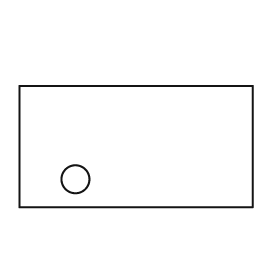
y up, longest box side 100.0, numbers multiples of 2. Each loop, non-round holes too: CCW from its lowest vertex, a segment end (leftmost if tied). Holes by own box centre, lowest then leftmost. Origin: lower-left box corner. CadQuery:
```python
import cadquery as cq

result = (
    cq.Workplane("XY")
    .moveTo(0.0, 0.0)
    .lineTo(100.0, 0.0)
    .lineTo(100.0, 52.0)
    .lineTo(0.0, 52.0)
    .close()
    .moveTo(24.0, 12.0)
    .circle(6.0)
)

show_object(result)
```